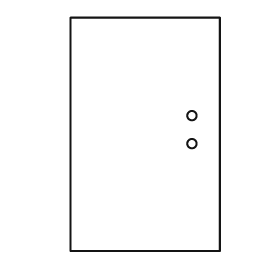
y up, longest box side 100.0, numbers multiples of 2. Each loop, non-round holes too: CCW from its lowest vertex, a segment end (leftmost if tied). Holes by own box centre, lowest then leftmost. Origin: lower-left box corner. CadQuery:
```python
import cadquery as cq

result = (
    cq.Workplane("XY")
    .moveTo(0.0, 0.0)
    .lineTo(64.0, 0.0)
    .lineTo(64.0, 100.0)
    .lineTo(0.0, 100.0)
    .close()
    .moveTo(52.0, 46.0)
    .circle(2.0)
    .moveTo(52.0, 58.0)
    .circle(2.0)
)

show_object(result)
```